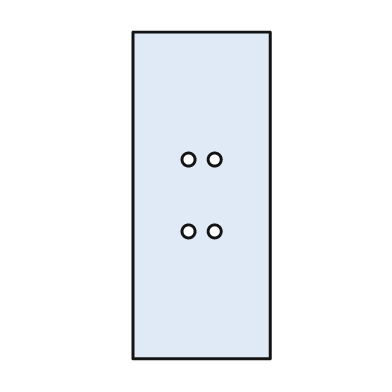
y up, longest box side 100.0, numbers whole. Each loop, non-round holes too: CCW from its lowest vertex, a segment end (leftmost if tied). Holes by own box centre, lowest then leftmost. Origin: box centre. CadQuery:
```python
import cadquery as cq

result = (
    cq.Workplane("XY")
    .moveTo(-21.0, -50.0)
    .lineTo(21.0, -50.0)
    .lineTo(21.0, 50.0)
    .lineTo(-21.0, 50.0)
    .close()
    .moveTo(-4.0, -11.0)
    .circle(2.0)
    .moveTo(4.0, -11.0)
    .circle(2.0)
    .moveTo(-4.0, 11.0)
    .circle(2.0)
    .moveTo(4.0, 11.0)
    .circle(2.0)
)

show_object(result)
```